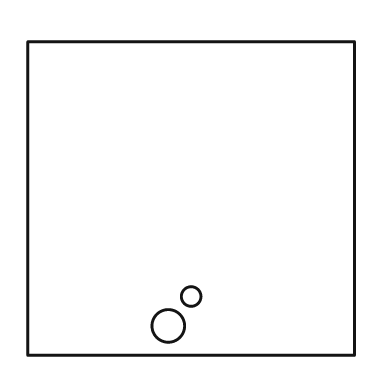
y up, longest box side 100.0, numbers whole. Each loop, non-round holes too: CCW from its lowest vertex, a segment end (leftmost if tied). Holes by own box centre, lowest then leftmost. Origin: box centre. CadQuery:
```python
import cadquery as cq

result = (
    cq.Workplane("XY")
    .moveTo(-50.0, -48.0)
    .lineTo(50.0, -48.0)
    .lineTo(50.0, 48.0)
    .lineTo(-50.0, 48.0)
    .close()
    .moveTo(-7.0, -39.0)
    .circle(5.0)
    .moveTo(0.0, -30.0)
    .circle(3.0)
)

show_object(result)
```